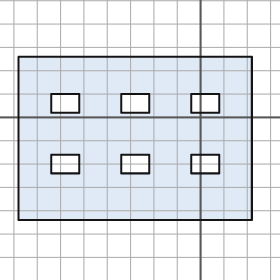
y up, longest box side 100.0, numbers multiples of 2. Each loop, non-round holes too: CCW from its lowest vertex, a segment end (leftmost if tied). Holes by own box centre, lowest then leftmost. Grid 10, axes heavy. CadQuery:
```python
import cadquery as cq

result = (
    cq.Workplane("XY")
    .moveTo(-78.0, -44.0)
    .lineTo(22.0, -44.0)
    .lineTo(22.0, 26.0)
    .lineTo(-78.0, 26.0)
    .close()
    .moveTo(-64.0, -24.0)
    .lineTo(-52.0, -24.0)
    .lineTo(-52.0, -16.0)
    .lineTo(-64.0, -16.0)
    .close()
    .moveTo(-34.0, -24.0)
    .lineTo(-22.0, -24.0)
    .lineTo(-22.0, -16.0)
    .lineTo(-34.0, -16.0)
    .close()
    .moveTo(-4.0, -24.0)
    .lineTo(8.0, -24.0)
    .lineTo(8.0, -16.0)
    .lineTo(-4.0, -16.0)
    .close()
    .moveTo(-64.0, 2.0)
    .lineTo(-52.0, 2.0)
    .lineTo(-52.0, 10.0)
    .lineTo(-64.0, 10.0)
    .close()
    .moveTo(-34.0, 2.0)
    .lineTo(-22.0, 2.0)
    .lineTo(-22.0, 10.0)
    .lineTo(-34.0, 10.0)
    .close()
    .moveTo(-4.0, 2.0)
    .lineTo(8.0, 2.0)
    .lineTo(8.0, 10.0)
    .lineTo(-4.0, 10.0)
    .close()
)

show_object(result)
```